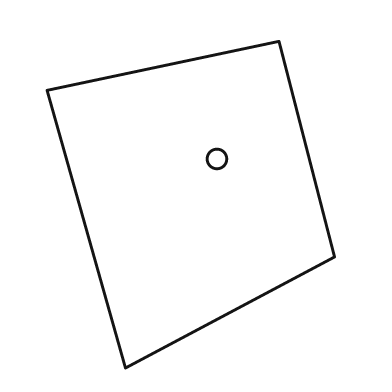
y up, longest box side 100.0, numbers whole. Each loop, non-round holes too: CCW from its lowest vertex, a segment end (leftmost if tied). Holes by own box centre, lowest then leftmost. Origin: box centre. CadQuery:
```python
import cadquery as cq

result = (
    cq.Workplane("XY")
    .moveTo(-20.0, -50.0)
    .lineTo(44.0, -16.0)
    .lineTo(27.0, 50.0)
    .lineTo(-44.0, 35.0)
    .close()
    .moveTo(8.0, 14.0)
    .circle(3.0)
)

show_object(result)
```